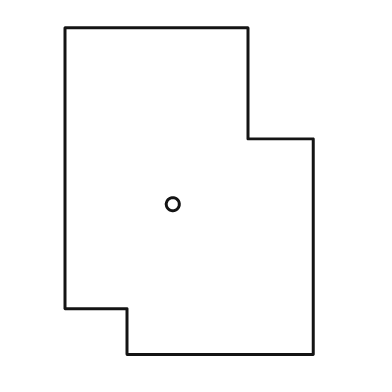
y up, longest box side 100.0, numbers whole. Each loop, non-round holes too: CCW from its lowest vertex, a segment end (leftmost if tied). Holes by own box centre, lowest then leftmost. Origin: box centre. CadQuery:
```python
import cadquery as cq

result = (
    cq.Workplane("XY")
    .moveTo(-19.0, -50.0)
    .lineTo(38.0, -50.0)
    .lineTo(38.0, 16.0)
    .lineTo(18.0, 16.0)
    .lineTo(18.0, 50.0)
    .lineTo(-38.0, 50.0)
    .lineTo(-38.0, -36.0)
    .lineTo(-19.0, -36.0)
    .close()
    .moveTo(-5.0, -4.0)
    .circle(2.0)
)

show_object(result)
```